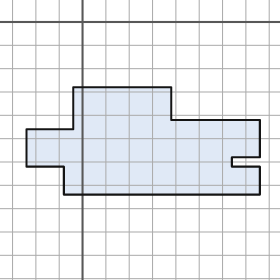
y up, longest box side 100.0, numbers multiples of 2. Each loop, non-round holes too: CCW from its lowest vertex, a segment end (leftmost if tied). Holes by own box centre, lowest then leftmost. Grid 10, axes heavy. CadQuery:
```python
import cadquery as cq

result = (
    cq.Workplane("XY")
    .moveTo(-8.0, -74.0)
    .lineTo(76.0, -74.0)
    .lineTo(76.0, -62.0)
    .lineTo(64.0, -62.0)
    .lineTo(64.0, -58.0)
    .lineTo(76.0, -58.0)
    .lineTo(76.0, -42.0)
    .lineTo(38.0, -42.0)
    .lineTo(38.0, -28.0)
    .lineTo(-4.0, -28.0)
    .lineTo(-4.0, -46.0)
    .lineTo(-24.0, -46.0)
    .lineTo(-24.0, -62.0)
    .lineTo(-8.0, -62.0)
    .close()
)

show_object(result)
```